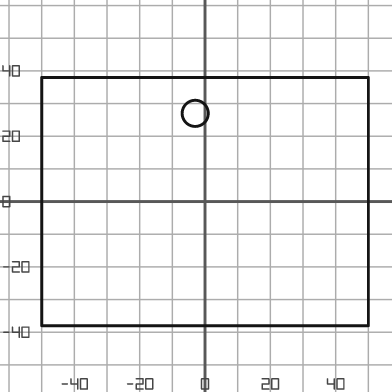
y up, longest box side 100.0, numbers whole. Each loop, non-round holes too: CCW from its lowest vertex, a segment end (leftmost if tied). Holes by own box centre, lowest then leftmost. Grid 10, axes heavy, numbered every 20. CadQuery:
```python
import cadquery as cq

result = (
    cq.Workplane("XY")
    .moveTo(-50.0, -38.0)
    .lineTo(50.0, -38.0)
    .lineTo(50.0, 38.0)
    .lineTo(-50.0, 38.0)
    .close()
    .moveTo(-3.0, 27.0)
    .circle(4.0)
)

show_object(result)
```